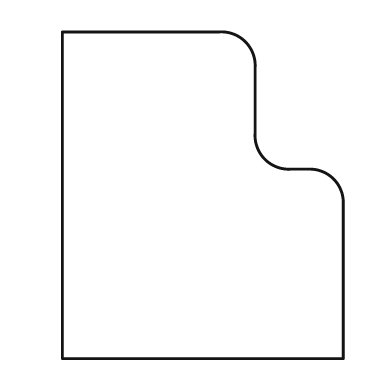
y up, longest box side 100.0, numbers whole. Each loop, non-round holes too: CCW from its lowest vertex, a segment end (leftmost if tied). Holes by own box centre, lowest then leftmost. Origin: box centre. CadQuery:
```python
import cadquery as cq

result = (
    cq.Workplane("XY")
    .moveTo(-43.0, -50.0)
    .lineTo(43.0, -50.0)
    .lineTo(43.0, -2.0)
    .threePointArc((40.0, 5.0), (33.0, 8.0))
    .lineTo(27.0, 8.0)
    .threePointArc((19.0, 11.0), (16.0, 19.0))
    .lineTo(16.0, 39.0)
    .threePointArc((13.0, 47.0), (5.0, 50.0))
    .lineTo(-43.0, 50.0)
    .close()
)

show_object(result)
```